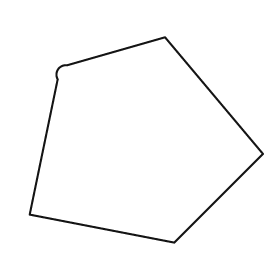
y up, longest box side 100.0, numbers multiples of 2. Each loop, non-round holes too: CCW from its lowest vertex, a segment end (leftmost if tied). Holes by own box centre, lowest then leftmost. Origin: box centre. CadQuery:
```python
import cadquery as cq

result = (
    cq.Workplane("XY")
    .moveTo(12.0, -44.0)
    .lineTo(50.0, -6.0)
    .lineTo(8.0, 44.0)
    .lineTo(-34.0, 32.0)
    .threePointArc((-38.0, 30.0), (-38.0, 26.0))
    .lineTo(-50.0, -32.0)
    .close()
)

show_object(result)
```